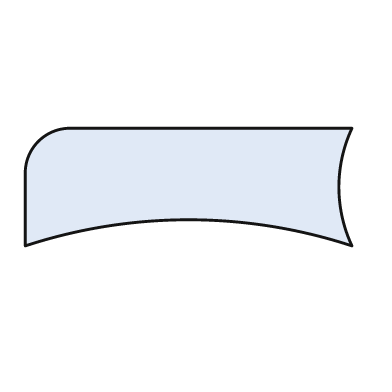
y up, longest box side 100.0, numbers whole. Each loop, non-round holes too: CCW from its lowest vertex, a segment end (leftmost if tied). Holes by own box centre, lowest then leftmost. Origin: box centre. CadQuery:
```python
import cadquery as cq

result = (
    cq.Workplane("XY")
    .moveTo(-50.0, -18.0)
    .threePointArc((0.0, -10.0), (50.0, -18.0))
    .threePointArc((46.0, 0.0), (50.0, 18.0))
    .lineTo(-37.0, 18.0)
    .threePointArc((-46.0, 14.0), (-50.0, 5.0))
    .close()
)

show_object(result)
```